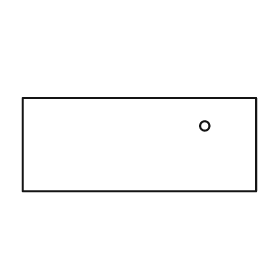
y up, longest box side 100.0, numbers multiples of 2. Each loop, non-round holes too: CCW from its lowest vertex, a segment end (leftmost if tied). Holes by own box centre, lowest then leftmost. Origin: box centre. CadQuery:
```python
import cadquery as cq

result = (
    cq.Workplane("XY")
    .moveTo(-50.0, -20.0)
    .lineTo(50.0, -20.0)
    .lineTo(50.0, 20.0)
    .lineTo(-50.0, 20.0)
    .close()
    .moveTo(28.0, 8.0)
    .circle(2.0)
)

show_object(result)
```